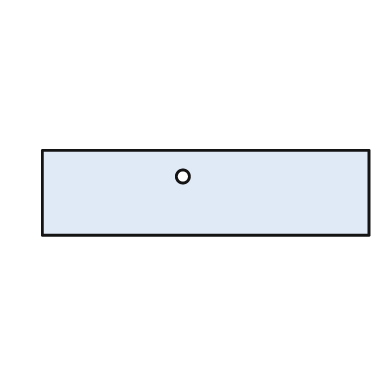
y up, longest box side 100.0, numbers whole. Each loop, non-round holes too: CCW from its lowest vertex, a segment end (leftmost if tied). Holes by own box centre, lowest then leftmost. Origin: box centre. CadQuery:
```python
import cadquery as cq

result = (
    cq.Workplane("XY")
    .moveTo(-50.0, -13.0)
    .lineTo(50.0, -13.0)
    .lineTo(50.0, 13.0)
    .lineTo(-50.0, 13.0)
    .close()
    .moveTo(-7.0, 5.0)
    .circle(2.0)
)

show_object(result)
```